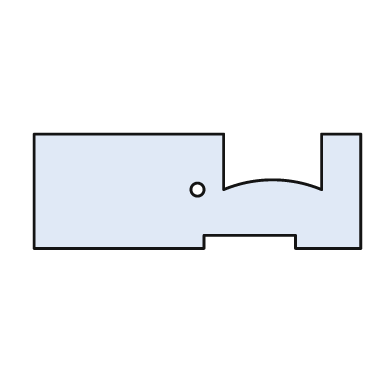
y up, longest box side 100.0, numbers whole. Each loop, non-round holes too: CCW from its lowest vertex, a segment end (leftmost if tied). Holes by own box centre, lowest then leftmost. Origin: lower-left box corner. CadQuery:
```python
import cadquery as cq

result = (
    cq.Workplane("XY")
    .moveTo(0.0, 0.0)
    .lineTo(52.0, 0.0)
    .lineTo(52.0, 4.0)
    .lineTo(80.0, 4.0)
    .lineTo(80.0, 0.0)
    .lineTo(100.0, 0.0)
    .lineTo(100.0, 35.0)
    .lineTo(88.0, 35.0)
    .lineTo(88.0, 18.0)
    .threePointArc((73.0, 21.0), (58.0, 18.0))
    .lineTo(58.0, 35.0)
    .lineTo(0.0, 35.0)
    .close()
    .moveTo(50.0, 18.0)
    .circle(2.0)
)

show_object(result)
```